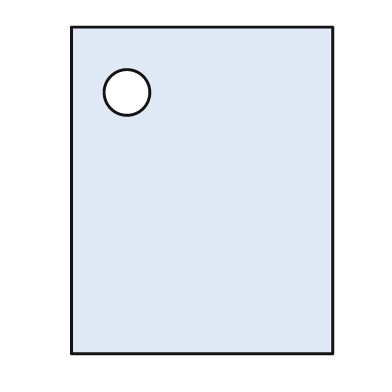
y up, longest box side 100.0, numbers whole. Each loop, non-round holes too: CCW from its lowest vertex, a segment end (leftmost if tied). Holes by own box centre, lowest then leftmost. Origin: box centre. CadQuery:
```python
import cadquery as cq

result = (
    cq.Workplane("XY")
    .moveTo(-40.0, -50.0)
    .lineTo(40.0, -50.0)
    .lineTo(40.0, 50.0)
    .lineTo(-40.0, 50.0)
    .close()
    .moveTo(-23.0, 30.0)
    .circle(7.0)
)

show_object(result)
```